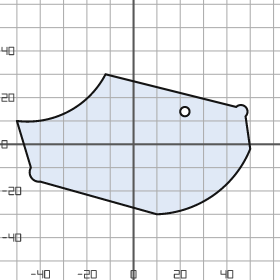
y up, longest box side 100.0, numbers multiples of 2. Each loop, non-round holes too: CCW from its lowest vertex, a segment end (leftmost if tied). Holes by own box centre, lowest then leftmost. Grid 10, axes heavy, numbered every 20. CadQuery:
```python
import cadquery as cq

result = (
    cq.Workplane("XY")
    .moveTo(10.0, -30.0)
    .threePointArc((34.0, -22.0), (50.0, -2.0))
    .lineTo(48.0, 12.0)
    .threePointArc((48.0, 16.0), (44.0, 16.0))
    .lineTo(-12.0, 30.0)
    .threePointArc((-28.0, 14.0), (-50.0, 10.0))
    .lineTo(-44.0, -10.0)
    .threePointArc((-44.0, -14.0), (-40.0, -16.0))
    .close()
    .moveTo(22.0, 14.0)
    .circle(2.0)
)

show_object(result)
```